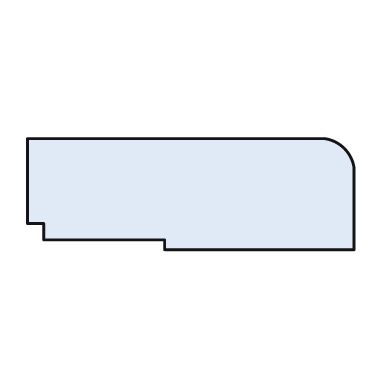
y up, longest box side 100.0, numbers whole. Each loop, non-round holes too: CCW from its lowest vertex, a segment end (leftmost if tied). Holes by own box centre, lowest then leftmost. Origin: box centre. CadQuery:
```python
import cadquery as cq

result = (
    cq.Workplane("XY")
    .moveTo(-8.0, -17.0)
    .lineTo(50.0, -17.0)
    .lineTo(50.0, 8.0)
    .threePointArc((47.0, 14.0), (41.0, 17.0))
    .lineTo(-50.0, 17.0)
    .lineTo(-50.0, -9.0)
    .lineTo(-45.0, -9.0)
    .lineTo(-45.0, -14.0)
    .lineTo(-8.0, -14.0)
    .close()
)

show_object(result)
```